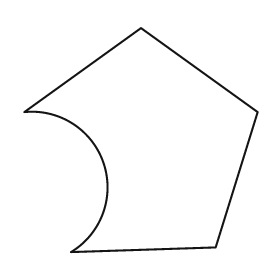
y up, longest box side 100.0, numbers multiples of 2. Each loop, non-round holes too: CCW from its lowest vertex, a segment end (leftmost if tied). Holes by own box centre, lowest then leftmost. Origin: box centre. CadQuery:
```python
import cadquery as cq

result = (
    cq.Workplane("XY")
    .moveTo(-30.0, -48.0)
    .lineTo(32.0, -46.0)
    .lineTo(50.0, 12.0)
    .lineTo(0.0, 48.0)
    .lineTo(-50.0, 12.0)
    .threePointArc((-16.0, -10.0), (-30.0, -48.0))
    .close()
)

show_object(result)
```